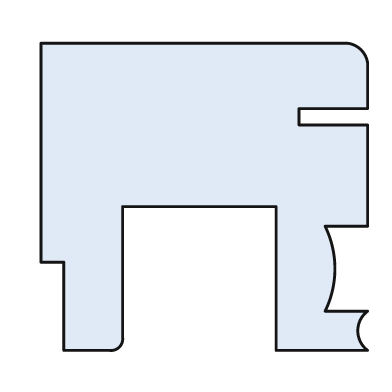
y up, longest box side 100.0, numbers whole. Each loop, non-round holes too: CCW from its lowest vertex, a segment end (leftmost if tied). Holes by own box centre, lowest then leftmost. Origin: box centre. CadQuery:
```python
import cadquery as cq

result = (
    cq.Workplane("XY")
    .moveTo(-43.0, -47.0)
    .lineTo(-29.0, -47.0)
    .threePointArc((-26.0, -46.0), (-25.0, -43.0))
    .lineTo(-25.0, -3.0)
    .lineTo(22.0, -3.0)
    .lineTo(22.0, -47.0)
    .lineTo(50.0, -47.0)
    .threePointArc((47.0, -41.0), (50.0, -35.0))
    .lineTo(37.0, -35.0)
    .threePointArc((40.0, -22.0), (37.0, -9.0))
    .lineTo(50.0, -9.0)
    .lineTo(50.0, 22.0)
    .lineTo(29.0, 22.0)
    .lineTo(29.0, 27.0)
    .lineTo(50.0, 27.0)
    .lineTo(50.0, 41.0)
    .threePointArc((48.0, 45.0), (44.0, 47.0))
    .lineTo(-50.0, 47.0)
    .lineTo(-50.0, -20.0)
    .lineTo(-43.0, -20.0)
    .close()
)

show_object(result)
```